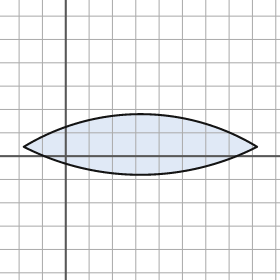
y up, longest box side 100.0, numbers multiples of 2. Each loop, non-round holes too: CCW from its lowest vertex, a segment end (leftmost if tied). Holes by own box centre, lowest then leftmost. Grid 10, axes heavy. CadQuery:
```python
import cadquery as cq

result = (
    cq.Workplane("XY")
    .moveTo(-18.0, 4.0)
    .threePointArc((32.0, -8.0), (82.0, 4.0))
    .threePointArc((32.0, 18.0), (-18.0, 4.0))
    .close()
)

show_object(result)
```